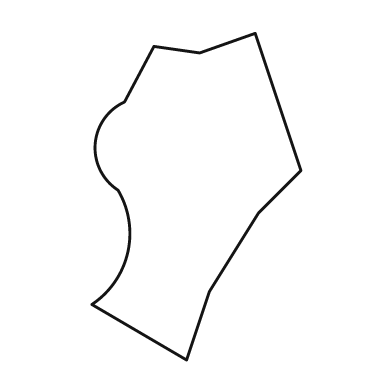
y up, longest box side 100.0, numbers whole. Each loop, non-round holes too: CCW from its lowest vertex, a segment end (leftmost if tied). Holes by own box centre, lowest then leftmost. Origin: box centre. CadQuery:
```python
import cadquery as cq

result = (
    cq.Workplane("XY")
    .moveTo(-3.0, -50.0)
    .lineTo(4.0, -29.0)
    .lineTo(19.0, -5.0)
    .lineTo(32.0, 8.0)
    .lineTo(18.0, 50.0)
    .lineTo(1.0, 44.0)
    .lineTo(-13.0, 46.0)
    .lineTo(-22.0, 29.0)
    .threePointArc((-31.0, 16.0), (-24.0, 2.0))
    .threePointArc((-21.0, -17.0), (-32.0, -33.0))
    .close()
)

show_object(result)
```